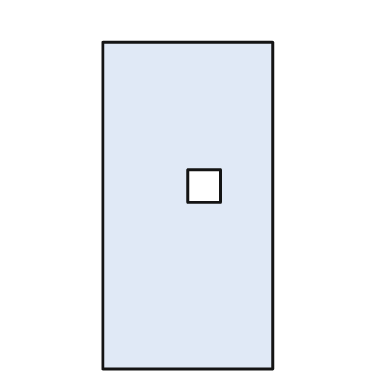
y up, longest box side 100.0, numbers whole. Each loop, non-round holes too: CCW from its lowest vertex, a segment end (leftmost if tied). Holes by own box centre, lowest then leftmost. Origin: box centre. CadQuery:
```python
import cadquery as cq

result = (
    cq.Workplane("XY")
    .moveTo(-26.0, -50.0)
    .lineTo(26.0, -50.0)
    .lineTo(26.0, 50.0)
    .lineTo(-26.0, 50.0)
    .close()
    .moveTo(0.0, 1.0)
    .lineTo(10.0, 1.0)
    .lineTo(10.0, 11.0)
    .lineTo(0.0, 11.0)
    .close()
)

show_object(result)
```